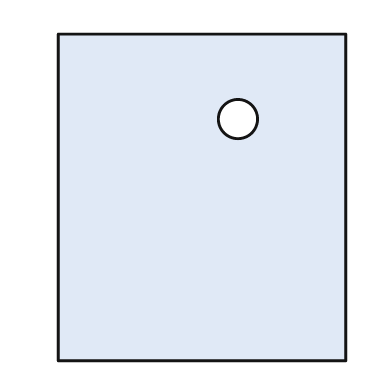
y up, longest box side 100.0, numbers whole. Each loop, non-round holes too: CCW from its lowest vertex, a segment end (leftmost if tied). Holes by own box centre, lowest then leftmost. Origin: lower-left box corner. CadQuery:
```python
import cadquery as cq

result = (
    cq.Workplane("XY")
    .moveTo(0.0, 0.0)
    .lineTo(88.0, 0.0)
    .lineTo(88.0, 100.0)
    .lineTo(0.0, 100.0)
    .close()
    .moveTo(55.0, 74.0)
    .circle(6.0)
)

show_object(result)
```